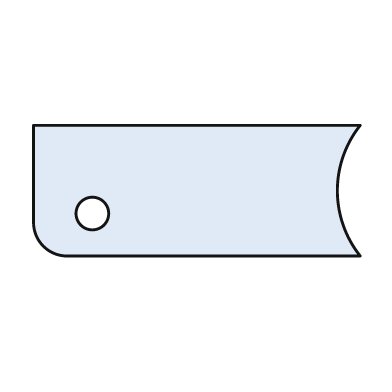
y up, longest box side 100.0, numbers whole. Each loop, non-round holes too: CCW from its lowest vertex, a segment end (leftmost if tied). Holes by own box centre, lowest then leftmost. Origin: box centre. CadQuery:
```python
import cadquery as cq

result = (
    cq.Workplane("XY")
    .moveTo(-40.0, -20.0)
    .lineTo(50.0, -20.0)
    .threePointArc((43.0, 0.0), (50.0, 20.0))
    .lineTo(-50.0, 20.0)
    .lineTo(-50.0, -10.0)
    .threePointArc((-47.0, -17.0), (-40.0, -20.0))
    .close()
    .moveTo(-32.0, -7.0)
    .circle(5.0)
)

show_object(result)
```